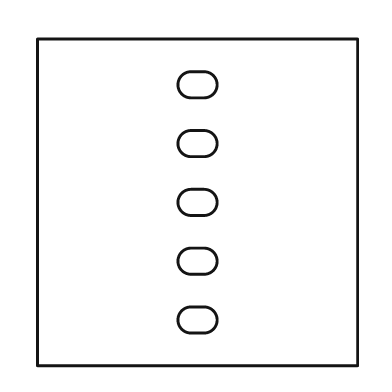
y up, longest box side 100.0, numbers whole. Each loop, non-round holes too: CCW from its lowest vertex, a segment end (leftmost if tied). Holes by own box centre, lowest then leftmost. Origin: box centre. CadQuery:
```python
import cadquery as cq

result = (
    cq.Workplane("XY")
    .moveTo(-49.0, -50.0)
    .lineTo(49.0, -50.0)
    .lineTo(49.0, 50.0)
    .lineTo(-49.0, 50.0)
    .close()
    .moveTo(-2.0, -40.0)
    .lineTo(2.0, -40.0)
    .threePointArc((6.0, -36.0), (2.0, -32.0))
    .lineTo(-2.0, -32.0)
    .threePointArc((-6.0, -36.0), (-2.0, -40.0))
    .close()
    .moveTo(-2.0, -22.0)
    .lineTo(2.0, -22.0)
    .threePointArc((6.0, -18.0), (2.0, -14.0))
    .lineTo(-2.0, -14.0)
    .threePointArc((-6.0, -18.0), (-2.0, -22.0))
    .close()
    .moveTo(-2.0, -4.0)
    .lineTo(2.0, -4.0)
    .threePointArc((6.0, 0.0), (2.0, 4.0))
    .lineTo(-2.0, 4.0)
    .threePointArc((-6.0, 0.0), (-2.0, -4.0))
    .close()
    .moveTo(-2.0, 14.0)
    .lineTo(2.0, 14.0)
    .threePointArc((6.0, 18.0), (2.0, 22.0))
    .lineTo(-2.0, 22.0)
    .threePointArc((-6.0, 18.0), (-2.0, 14.0))
    .close()
    .moveTo(-2.0, 32.0)
    .lineTo(2.0, 32.0)
    .threePointArc((6.0, 36.0), (2.0, 40.0))
    .lineTo(-2.0, 40.0)
    .threePointArc((-6.0, 36.0), (-2.0, 32.0))
    .close()
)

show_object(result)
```